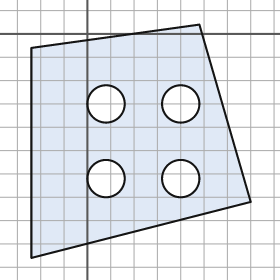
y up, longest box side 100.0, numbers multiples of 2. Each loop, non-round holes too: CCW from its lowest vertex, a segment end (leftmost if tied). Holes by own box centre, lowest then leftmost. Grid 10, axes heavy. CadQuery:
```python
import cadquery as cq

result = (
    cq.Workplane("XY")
    .moveTo(-24.0, -96.0)
    .lineTo(70.0, -72.0)
    .lineTo(48.0, 4.0)
    .lineTo(-24.0, -6.0)
    .close()
    .moveTo(8.0, -62.0)
    .circle(8.0)
    .moveTo(40.0, -62.0)
    .circle(8.0)
    .moveTo(8.0, -30.0)
    .circle(8.0)
    .moveTo(40.0, -30.0)
    .circle(8.0)
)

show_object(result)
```